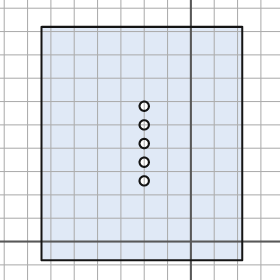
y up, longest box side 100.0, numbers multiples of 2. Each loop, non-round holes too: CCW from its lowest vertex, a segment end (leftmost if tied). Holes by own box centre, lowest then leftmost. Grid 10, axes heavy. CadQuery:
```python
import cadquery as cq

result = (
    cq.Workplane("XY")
    .moveTo(-64.0, -8.0)
    .lineTo(22.0, -8.0)
    .lineTo(22.0, 92.0)
    .lineTo(-64.0, 92.0)
    .close()
    .moveTo(-20.0, 26.0)
    .circle(2.0)
    .moveTo(-20.0, 34.0)
    .circle(2.0)
    .moveTo(-20.0, 42.0)
    .circle(2.0)
    .moveTo(-20.0, 50.0)
    .circle(2.0)
    .moveTo(-20.0, 58.0)
    .circle(2.0)
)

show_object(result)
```